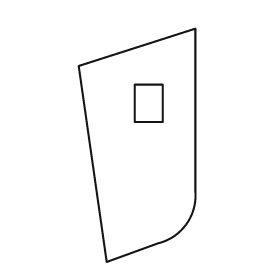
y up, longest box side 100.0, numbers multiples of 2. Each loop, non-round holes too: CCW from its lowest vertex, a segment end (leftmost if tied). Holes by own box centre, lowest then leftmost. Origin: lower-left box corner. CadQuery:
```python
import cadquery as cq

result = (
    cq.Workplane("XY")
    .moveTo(12.0, 0.0)
    .lineTo(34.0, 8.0)
    .threePointArc((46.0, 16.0), (50.0, 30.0))
    .lineTo(50.0, 100.0)
    .lineTo(0.0, 84.0)
    .close()
    .moveTo(24.0, 60.0)
    .lineTo(36.0, 60.0)
    .lineTo(36.0, 76.0)
    .lineTo(24.0, 76.0)
    .close()
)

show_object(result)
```